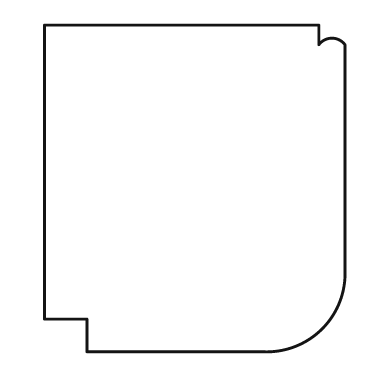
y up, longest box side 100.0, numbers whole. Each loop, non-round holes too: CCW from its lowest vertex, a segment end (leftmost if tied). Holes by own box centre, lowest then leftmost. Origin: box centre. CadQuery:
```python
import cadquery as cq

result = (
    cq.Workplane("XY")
    .moveTo(-33.0, -50.0)
    .lineTo(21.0, -50.0)
    .threePointArc((39.0, -43.0), (46.0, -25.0))
    .lineTo(46.0, 44.0)
    .threePointArc((42.0, 46.0), (38.0, 44.0))
    .lineTo(38.0, 50.0)
    .lineTo(-46.0, 50.0)
    .lineTo(-46.0, -40.0)
    .lineTo(-33.0, -40.0)
    .close()
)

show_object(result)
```